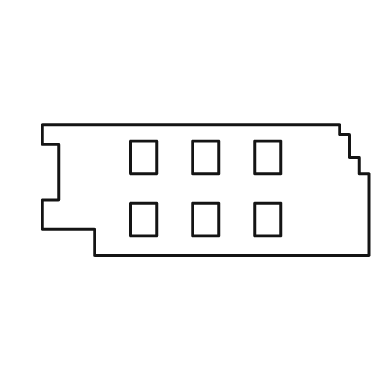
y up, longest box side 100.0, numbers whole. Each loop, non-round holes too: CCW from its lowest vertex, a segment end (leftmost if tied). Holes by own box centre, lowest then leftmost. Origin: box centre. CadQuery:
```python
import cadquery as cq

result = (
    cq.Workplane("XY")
    .moveTo(-34.0, -20.0)
    .lineTo(50.0, -20.0)
    .lineTo(50.0, 5.0)
    .lineTo(47.0, 5.0)
    .lineTo(47.0, 10.0)
    .lineTo(44.0, 10.0)
    .lineTo(44.0, 17.0)
    .lineTo(41.0, 17.0)
    .lineTo(41.0, 20.0)
    .lineTo(-50.0, 20.0)
    .lineTo(-50.0, 14.0)
    .lineTo(-45.0, 14.0)
    .lineTo(-45.0, -3.0)
    .lineTo(-50.0, -3.0)
    .lineTo(-50.0, -12.0)
    .lineTo(-34.0, -12.0)
    .close()
    .moveTo(-23.0, -14.0)
    .lineTo(-15.0, -14.0)
    .lineTo(-15.0, -4.0)
    .lineTo(-23.0, -4.0)
    .close()
    .moveTo(-4.0, -14.0)
    .lineTo(4.0, -14.0)
    .lineTo(4.0, -4.0)
    .lineTo(-4.0, -4.0)
    .close()
    .moveTo(15.0, -14.0)
    .lineTo(23.0, -14.0)
    .lineTo(23.0, -4.0)
    .lineTo(15.0, -4.0)
    .close()
    .moveTo(-23.0, 5.0)
    .lineTo(-15.0, 5.0)
    .lineTo(-15.0, 15.0)
    .lineTo(-23.0, 15.0)
    .close()
    .moveTo(-4.0, 5.0)
    .lineTo(4.0, 5.0)
    .lineTo(4.0, 15.0)
    .lineTo(-4.0, 15.0)
    .close()
    .moveTo(15.0, 5.0)
    .lineTo(23.0, 5.0)
    .lineTo(23.0, 15.0)
    .lineTo(15.0, 15.0)
    .close()
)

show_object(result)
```